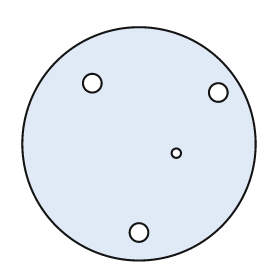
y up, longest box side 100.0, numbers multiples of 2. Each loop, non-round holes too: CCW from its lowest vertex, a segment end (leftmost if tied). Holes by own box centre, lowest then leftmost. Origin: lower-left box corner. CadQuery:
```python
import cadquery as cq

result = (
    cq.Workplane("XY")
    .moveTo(50.0, 50.0)
    .circle(50.0)
    .moveTo(50.0, 12.0)
    .circle(4.0)
    .moveTo(66.0, 46.0)
    .circle(2.0)
    .moveTo(84.0, 72.0)
    .circle(4.0)
    .moveTo(30.0, 76.0)
    .circle(4.0)
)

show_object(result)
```